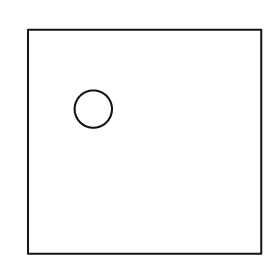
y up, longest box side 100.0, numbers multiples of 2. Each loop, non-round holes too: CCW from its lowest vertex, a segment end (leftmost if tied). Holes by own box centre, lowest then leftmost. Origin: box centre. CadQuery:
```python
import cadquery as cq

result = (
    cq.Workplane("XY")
    .moveTo(-50.0, -48.0)
    .lineTo(50.0, -48.0)
    .lineTo(50.0, 48.0)
    .lineTo(-50.0, 48.0)
    .close()
    .moveTo(-22.0, 14.0)
    .circle(8.0)
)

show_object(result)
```